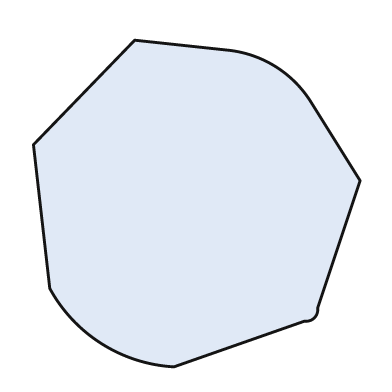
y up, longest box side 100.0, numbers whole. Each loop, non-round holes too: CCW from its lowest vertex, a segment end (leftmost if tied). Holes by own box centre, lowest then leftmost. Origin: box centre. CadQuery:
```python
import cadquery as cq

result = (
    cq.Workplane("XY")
    .moveTo(-7.0, -50.0)
    .lineTo(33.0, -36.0)
    .threePointArc((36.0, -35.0), (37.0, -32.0))
    .lineTo(50.0, 7.0)
    .lineTo(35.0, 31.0)
    .threePointArc((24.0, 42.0), (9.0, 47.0))
    .lineTo(-19.0, 50.0)
    .lineTo(-50.0, 18.0)
    .lineTo(-45.0, -26.0)
    .threePointArc((-29.0, -43.0), (-7.0, -50.0))
    .close()
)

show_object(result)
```